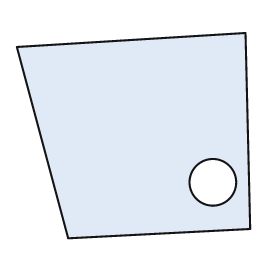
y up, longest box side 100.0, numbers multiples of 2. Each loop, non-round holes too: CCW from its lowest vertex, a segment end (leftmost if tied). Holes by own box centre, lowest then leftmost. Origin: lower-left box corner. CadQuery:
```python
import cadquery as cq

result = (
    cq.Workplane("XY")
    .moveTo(22.0, 0.0)
    .lineTo(100.0, 4.0)
    .lineTo(98.0, 88.0)
    .lineTo(0.0, 82.0)
    .close()
    .moveTo(84.0, 24.0)
    .circle(10.0)
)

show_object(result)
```